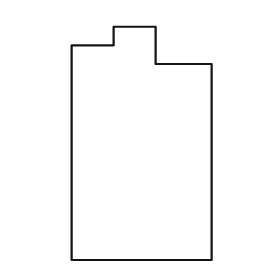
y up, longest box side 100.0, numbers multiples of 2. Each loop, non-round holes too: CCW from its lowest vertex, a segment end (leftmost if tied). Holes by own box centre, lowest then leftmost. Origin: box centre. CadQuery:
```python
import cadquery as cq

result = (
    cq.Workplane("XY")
    .moveTo(-30.0, -50.0)
    .lineTo(30.0, -50.0)
    .lineTo(30.0, 34.0)
    .lineTo(6.0, 34.0)
    .lineTo(6.0, 50.0)
    .lineTo(-12.0, 50.0)
    .lineTo(-12.0, 42.0)
    .lineTo(-30.0, 42.0)
    .close()
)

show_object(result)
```